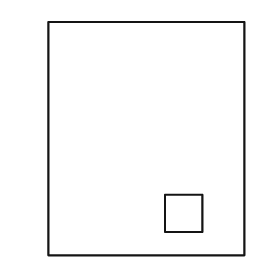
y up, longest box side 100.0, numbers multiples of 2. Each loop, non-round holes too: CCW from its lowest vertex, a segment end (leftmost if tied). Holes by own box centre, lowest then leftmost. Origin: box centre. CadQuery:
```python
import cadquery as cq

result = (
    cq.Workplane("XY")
    .moveTo(-42.0, -50.0)
    .lineTo(42.0, -50.0)
    .lineTo(42.0, 50.0)
    .lineTo(-42.0, 50.0)
    .close()
    .moveTo(8.0, -40.0)
    .lineTo(24.0, -40.0)
    .lineTo(24.0, -24.0)
    .lineTo(8.0, -24.0)
    .close()
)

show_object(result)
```